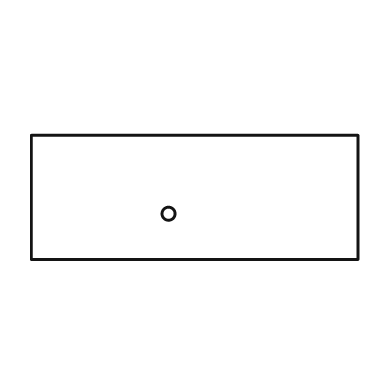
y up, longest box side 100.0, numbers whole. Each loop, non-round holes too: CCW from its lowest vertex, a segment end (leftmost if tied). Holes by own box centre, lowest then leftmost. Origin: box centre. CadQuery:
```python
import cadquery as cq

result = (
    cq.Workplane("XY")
    .moveTo(-50.0, -19.0)
    .lineTo(50.0, -19.0)
    .lineTo(50.0, 19.0)
    .lineTo(-50.0, 19.0)
    .close()
    .moveTo(-8.0, -5.0)
    .circle(2.0)
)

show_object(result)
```